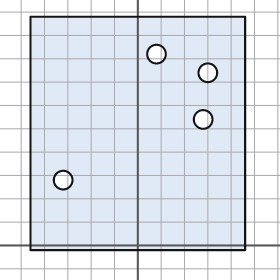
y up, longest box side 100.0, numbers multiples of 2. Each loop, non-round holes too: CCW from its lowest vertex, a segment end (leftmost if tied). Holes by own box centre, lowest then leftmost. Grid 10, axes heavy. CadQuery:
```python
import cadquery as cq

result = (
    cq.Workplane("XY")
    .moveTo(-46.0, -2.0)
    .lineTo(46.0, -2.0)
    .lineTo(46.0, 98.0)
    .lineTo(-46.0, 98.0)
    .close()
    .moveTo(-32.0, 28.0)
    .circle(4.0)
    .moveTo(28.0, 54.0)
    .circle(4.0)
    .moveTo(30.0, 74.0)
    .circle(4.0)
    .moveTo(8.0, 82.0)
    .circle(4.0)
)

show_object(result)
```